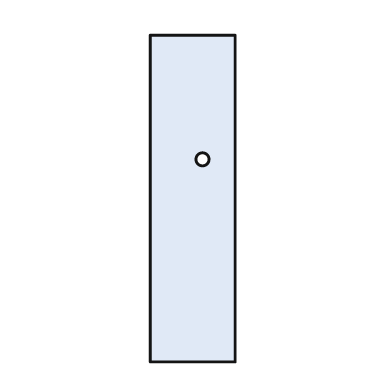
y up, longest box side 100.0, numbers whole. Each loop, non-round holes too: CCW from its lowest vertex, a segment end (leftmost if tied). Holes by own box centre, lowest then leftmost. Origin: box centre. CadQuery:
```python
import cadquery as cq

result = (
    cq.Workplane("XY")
    .moveTo(-13.0, -50.0)
    .lineTo(13.0, -50.0)
    .lineTo(13.0, 50.0)
    .lineTo(-13.0, 50.0)
    .close()
    .moveTo(3.0, 12.0)
    .circle(2.0)
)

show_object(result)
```